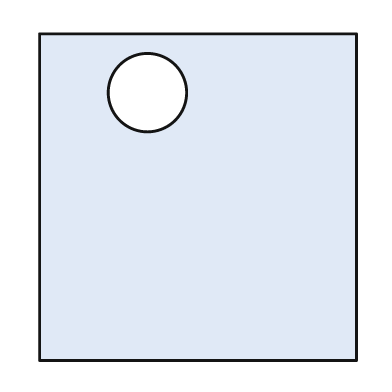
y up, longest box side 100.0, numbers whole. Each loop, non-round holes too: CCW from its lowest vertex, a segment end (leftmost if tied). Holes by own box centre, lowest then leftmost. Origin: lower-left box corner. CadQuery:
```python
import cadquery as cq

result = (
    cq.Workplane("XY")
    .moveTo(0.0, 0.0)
    .lineTo(97.0, 0.0)
    .lineTo(97.0, 100.0)
    .lineTo(0.0, 100.0)
    .close()
    .moveTo(33.0, 82.0)
    .circle(12.0)
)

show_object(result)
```